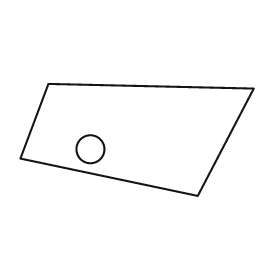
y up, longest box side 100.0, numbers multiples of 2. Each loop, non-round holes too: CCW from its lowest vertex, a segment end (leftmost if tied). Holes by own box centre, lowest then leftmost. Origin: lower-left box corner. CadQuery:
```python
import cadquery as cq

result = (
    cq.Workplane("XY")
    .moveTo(76.0, 0.0)
    .lineTo(100.0, 46.0)
    .lineTo(12.0, 48.0)
    .lineTo(0.0, 16.0)
    .close()
    .moveTo(30.0, 20.0)
    .circle(6.0)
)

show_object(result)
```